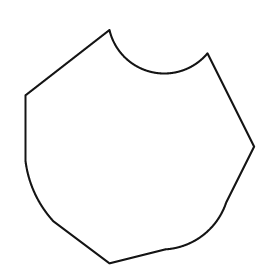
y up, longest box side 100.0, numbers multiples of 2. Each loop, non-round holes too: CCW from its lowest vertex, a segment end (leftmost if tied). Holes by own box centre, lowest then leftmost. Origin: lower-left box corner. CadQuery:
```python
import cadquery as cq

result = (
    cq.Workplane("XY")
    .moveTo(36.0, 0.0)
    .lineTo(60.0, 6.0)
    .threePointArc((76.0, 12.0), (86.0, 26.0))
    .lineTo(98.0, 50.0)
    .lineTo(78.0, 90.0)
    .threePointArc((54.0, 82.0), (36.0, 100.0))
    .lineTo(0.0, 72.0)
    .lineTo(0.0, 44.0)
    .threePointArc((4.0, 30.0), (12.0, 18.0))
    .close()
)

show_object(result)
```